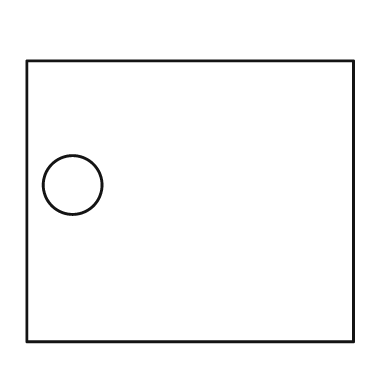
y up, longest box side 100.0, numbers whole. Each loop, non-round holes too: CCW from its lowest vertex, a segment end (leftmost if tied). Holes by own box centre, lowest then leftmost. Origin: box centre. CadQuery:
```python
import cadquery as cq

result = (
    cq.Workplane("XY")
    .moveTo(-50.0, -43.0)
    .lineTo(50.0, -43.0)
    .lineTo(50.0, 43.0)
    .lineTo(-50.0, 43.0)
    .close()
    .moveTo(-36.0, 5.0)
    .circle(9.0)
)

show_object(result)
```